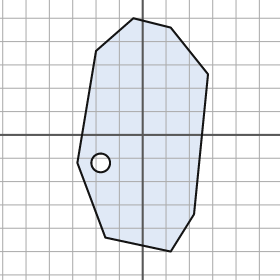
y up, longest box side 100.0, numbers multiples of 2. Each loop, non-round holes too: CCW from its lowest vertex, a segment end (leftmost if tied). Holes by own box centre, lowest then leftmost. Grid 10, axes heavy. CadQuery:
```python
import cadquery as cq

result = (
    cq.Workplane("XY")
    .moveTo(12.0, -50.0)
    .lineTo(22.0, -34.0)
    .lineTo(28.0, 26.0)
    .lineTo(12.0, 46.0)
    .lineTo(-4.0, 50.0)
    .lineTo(-20.0, 36.0)
    .lineTo(-28.0, -12.0)
    .lineTo(-16.0, -44.0)
    .close()
    .moveTo(-18.0, -12.0)
    .circle(4.0)
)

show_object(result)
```